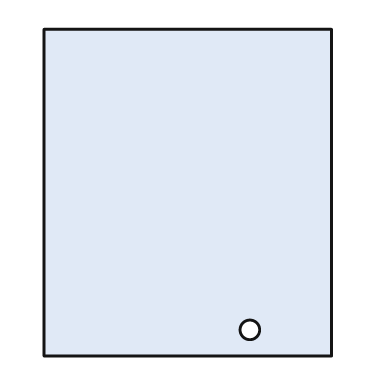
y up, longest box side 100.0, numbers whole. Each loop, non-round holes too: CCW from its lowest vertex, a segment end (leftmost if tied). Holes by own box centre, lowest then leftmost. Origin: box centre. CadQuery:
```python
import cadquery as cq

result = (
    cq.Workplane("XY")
    .moveTo(-44.0, -50.0)
    .lineTo(44.0, -50.0)
    .lineTo(44.0, 50.0)
    .lineTo(-44.0, 50.0)
    .close()
    .moveTo(19.0, -42.0)
    .circle(3.0)
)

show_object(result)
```